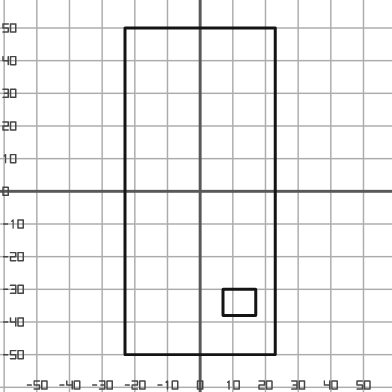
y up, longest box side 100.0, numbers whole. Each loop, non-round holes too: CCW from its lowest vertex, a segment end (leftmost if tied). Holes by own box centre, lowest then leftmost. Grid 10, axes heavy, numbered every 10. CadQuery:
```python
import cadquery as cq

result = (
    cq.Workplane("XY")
    .moveTo(-23.0, -50.0)
    .lineTo(23.0, -50.0)
    .lineTo(23.0, 50.0)
    .lineTo(-23.0, 50.0)
    .close()
    .moveTo(7.0, -38.0)
    .lineTo(17.0, -38.0)
    .lineTo(17.0, -30.0)
    .lineTo(7.0, -30.0)
    .close()
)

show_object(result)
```